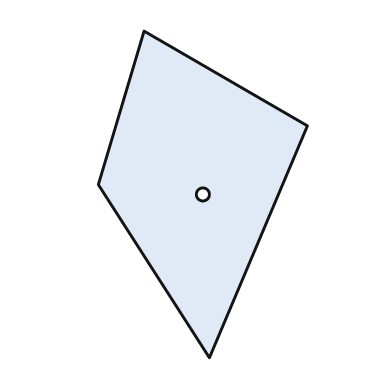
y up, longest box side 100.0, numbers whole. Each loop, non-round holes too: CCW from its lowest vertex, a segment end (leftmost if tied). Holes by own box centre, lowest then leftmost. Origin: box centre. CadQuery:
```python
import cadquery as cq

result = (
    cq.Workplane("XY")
    .moveTo(2.0, -50.0)
    .lineTo(32.0, 21.0)
    .lineTo(-18.0, 50.0)
    .lineTo(-32.0, 3.0)
    .close()
    .moveTo(0.0, 0.0)
    .circle(2.0)
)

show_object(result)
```